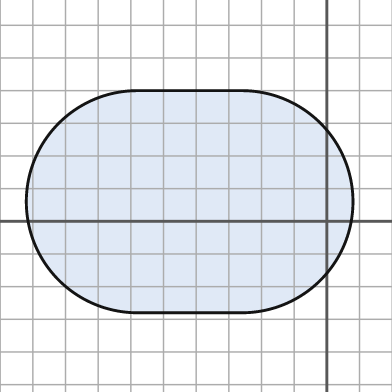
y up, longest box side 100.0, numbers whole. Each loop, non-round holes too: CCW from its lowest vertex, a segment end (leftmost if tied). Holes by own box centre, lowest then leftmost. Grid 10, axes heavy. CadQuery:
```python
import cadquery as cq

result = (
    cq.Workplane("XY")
    .moveTo(-58.0, -28.0)
    .lineTo(-26.0, -28.0)
    .threePointArc((8.0, 6.0), (-26.0, 40.0))
    .lineTo(-58.0, 40.0)
    .threePointArc((-92.0, 6.0), (-58.0, -28.0))
    .close()
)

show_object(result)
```